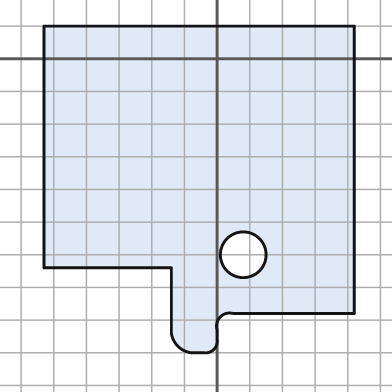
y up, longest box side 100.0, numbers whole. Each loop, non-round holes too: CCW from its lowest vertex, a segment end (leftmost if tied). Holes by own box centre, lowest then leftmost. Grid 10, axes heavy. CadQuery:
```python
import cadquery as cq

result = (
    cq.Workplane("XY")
    .moveTo(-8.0, -90.0)
    .lineTo(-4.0, -90.0)
    .threePointArc((-1.0, -89.0), (0.0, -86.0))
    .lineTo(0.0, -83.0)
    .threePointArc((1.0, -79.0), (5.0, -78.0))
    .lineTo(42.0, -78.0)
    .lineTo(42.0, 10.0)
    .lineTo(-53.0, 10.0)
    .lineTo(-53.0, -64.0)
    .lineTo(-14.0, -64.0)
    .lineTo(-14.0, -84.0)
    .threePointArc((-12.0, -88.0), (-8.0, -90.0))
    .close()
    .moveTo(8.0, -60.0)
    .circle(7.0)
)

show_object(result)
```